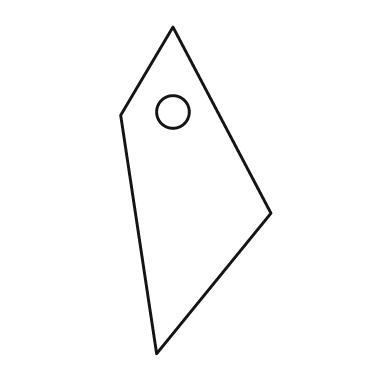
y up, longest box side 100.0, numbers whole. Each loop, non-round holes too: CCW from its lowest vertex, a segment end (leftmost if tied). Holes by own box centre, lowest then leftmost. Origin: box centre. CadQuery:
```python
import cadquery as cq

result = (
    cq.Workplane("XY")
    .moveTo(-12.0, -50.0)
    .lineTo(23.0, -7.0)
    .lineTo(-7.0, 50.0)
    .lineTo(-23.0, 23.0)
    .close()
    .moveTo(-7.0, 24.0)
    .circle(5.0)
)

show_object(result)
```